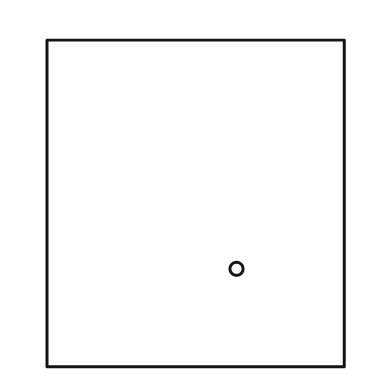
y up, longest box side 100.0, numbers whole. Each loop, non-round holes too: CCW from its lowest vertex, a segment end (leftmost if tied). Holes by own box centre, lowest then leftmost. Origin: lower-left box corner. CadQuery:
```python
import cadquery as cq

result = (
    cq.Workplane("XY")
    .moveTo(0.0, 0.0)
    .lineTo(91.0, 0.0)
    .lineTo(91.0, 100.0)
    .lineTo(0.0, 100.0)
    .close()
    .moveTo(58.0, 30.0)
    .circle(2.0)
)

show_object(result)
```